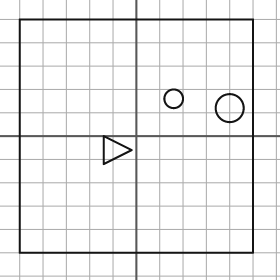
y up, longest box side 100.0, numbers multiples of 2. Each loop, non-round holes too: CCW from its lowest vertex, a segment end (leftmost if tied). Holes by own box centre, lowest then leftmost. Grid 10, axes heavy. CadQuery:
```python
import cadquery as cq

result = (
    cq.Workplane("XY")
    .moveTo(-50.0, -50.0)
    .lineTo(50.0, -50.0)
    .lineTo(50.0, 50.0)
    .lineTo(-50.0, 50.0)
    .close()
    .moveTo(-14.0, -12.0)
    .lineTo(-2.0, -6.0)
    .lineTo(-14.0, 0.0)
    .close()
    .moveTo(40.0, 12.0)
    .circle(6.0)
    .moveTo(16.0, 16.0)
    .circle(4.0)
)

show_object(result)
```